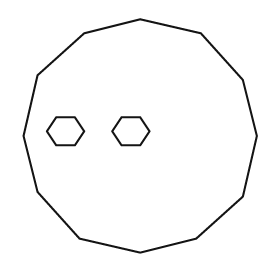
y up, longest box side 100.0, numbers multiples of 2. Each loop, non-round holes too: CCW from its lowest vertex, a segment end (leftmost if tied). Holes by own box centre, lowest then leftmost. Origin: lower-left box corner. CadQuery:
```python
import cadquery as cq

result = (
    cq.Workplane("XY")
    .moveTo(50.0, 0.0)
    .lineTo(74.0, 6.0)
    .lineTo(94.0, 24.0)
    .lineTo(100.0, 50.0)
    .lineTo(94.0, 74.0)
    .lineTo(76.0, 94.0)
    .lineTo(50.0, 100.0)
    .lineTo(26.0, 94.0)
    .lineTo(6.0, 76.0)
    .lineTo(0.0, 50.0)
    .lineTo(6.0, 26.0)
    .lineTo(24.0, 6.0)
    .close()
    .moveTo(14.0, 46.0)
    .lineTo(22.0, 46.0)
    .lineTo(26.0, 52.0)
    .lineTo(22.0, 58.0)
    .lineTo(14.0, 58.0)
    .lineTo(10.0, 52.0)
    .close()
    .moveTo(42.0, 46.0)
    .lineTo(50.0, 46.0)
    .lineTo(54.0, 52.0)
    .lineTo(50.0, 58.0)
    .lineTo(42.0, 58.0)
    .lineTo(38.0, 52.0)
    .close()
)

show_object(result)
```